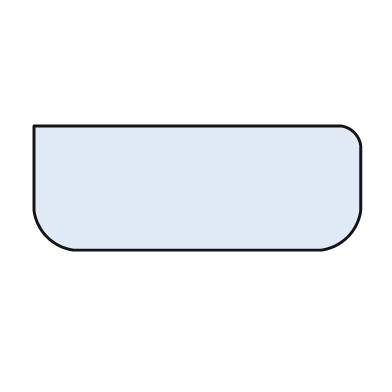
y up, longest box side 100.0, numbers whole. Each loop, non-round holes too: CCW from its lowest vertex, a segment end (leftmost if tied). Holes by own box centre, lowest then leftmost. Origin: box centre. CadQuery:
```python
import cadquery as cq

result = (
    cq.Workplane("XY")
    .moveTo(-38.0, -19.0)
    .lineTo(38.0, -19.0)
    .threePointArc((46.0, -15.0), (50.0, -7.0))
    .lineTo(50.0, 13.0)
    .threePointArc((48.0, 17.0), (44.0, 19.0))
    .lineTo(-50.0, 19.0)
    .lineTo(-50.0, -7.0)
    .threePointArc((-46.0, -15.0), (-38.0, -19.0))
    .close()
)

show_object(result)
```